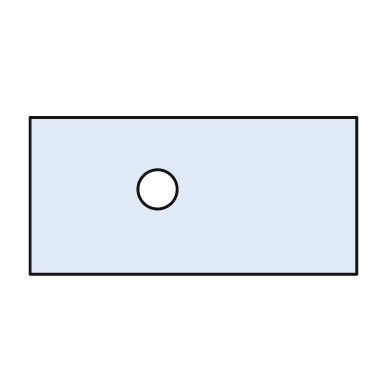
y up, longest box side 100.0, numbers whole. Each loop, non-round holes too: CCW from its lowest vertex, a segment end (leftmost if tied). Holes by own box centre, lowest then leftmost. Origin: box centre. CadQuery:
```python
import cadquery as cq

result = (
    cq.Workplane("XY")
    .moveTo(-50.0, -24.0)
    .lineTo(50.0, -24.0)
    .lineTo(50.0, 24.0)
    .lineTo(-50.0, 24.0)
    .close()
    .moveTo(-11.0, 2.0)
    .circle(6.0)
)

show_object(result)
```